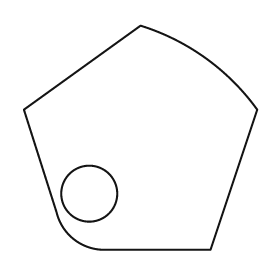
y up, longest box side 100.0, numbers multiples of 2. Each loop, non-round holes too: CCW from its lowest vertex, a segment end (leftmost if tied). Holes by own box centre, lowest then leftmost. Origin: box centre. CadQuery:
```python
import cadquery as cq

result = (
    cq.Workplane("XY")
    .moveTo(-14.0, -48.0)
    .lineTo(30.0, -48.0)
    .lineTo(50.0, 12.0)
    .threePointArc((28.0, 34.0), (0.0, 48.0))
    .lineTo(-50.0, 12.0)
    .lineTo(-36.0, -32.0)
    .threePointArc((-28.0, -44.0), (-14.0, -48.0))
    .close()
    .moveTo(-22.0, -24.0)
    .circle(12.0)
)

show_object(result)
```